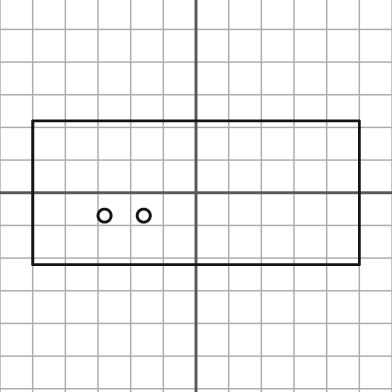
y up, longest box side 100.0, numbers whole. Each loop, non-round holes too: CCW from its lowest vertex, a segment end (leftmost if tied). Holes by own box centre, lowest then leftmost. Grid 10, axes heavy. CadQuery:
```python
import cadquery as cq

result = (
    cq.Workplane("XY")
    .moveTo(-50.0, -22.0)
    .lineTo(50.0, -22.0)
    .lineTo(50.0, 22.0)
    .lineTo(-50.0, 22.0)
    .close()
    .moveTo(-28.0, -7.0)
    .circle(2.0)
    .moveTo(-16.0, -7.0)
    .circle(2.0)
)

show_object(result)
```